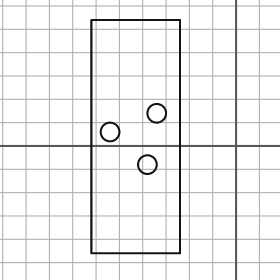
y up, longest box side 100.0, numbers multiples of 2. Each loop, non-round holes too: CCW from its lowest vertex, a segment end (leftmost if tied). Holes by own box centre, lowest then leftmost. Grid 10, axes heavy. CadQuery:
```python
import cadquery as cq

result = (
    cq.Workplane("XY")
    .moveTo(-62.0, -46.0)
    .lineTo(-24.0, -46.0)
    .lineTo(-24.0, 54.0)
    .lineTo(-62.0, 54.0)
    .close()
    .moveTo(-38.0, -8.0)
    .circle(4.0)
    .moveTo(-54.0, 6.0)
    .circle(4.0)
    .moveTo(-34.0, 14.0)
    .circle(4.0)
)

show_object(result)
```